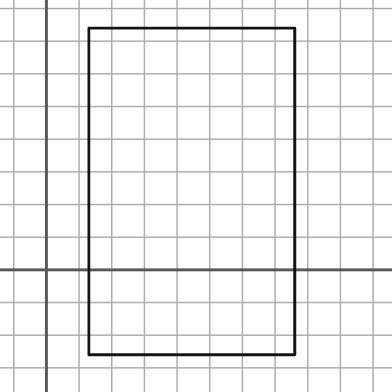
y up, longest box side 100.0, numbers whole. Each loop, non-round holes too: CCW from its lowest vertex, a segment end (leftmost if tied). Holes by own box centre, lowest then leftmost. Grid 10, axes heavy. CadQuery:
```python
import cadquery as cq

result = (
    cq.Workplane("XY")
    .moveTo(13.0, -26.0)
    .lineTo(76.0, -26.0)
    .lineTo(76.0, 74.0)
    .lineTo(13.0, 74.0)
    .close()
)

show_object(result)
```